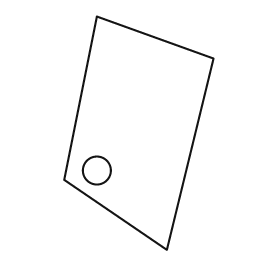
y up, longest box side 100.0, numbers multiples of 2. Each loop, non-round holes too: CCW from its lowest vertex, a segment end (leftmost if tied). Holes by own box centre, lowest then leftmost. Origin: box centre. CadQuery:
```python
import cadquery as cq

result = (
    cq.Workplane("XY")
    .moveTo(12.0, -50.0)
    .lineTo(32.0, 32.0)
    .lineTo(-18.0, 50.0)
    .lineTo(-32.0, -20.0)
    .close()
    .moveTo(-18.0, -16.0)
    .circle(6.0)
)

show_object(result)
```